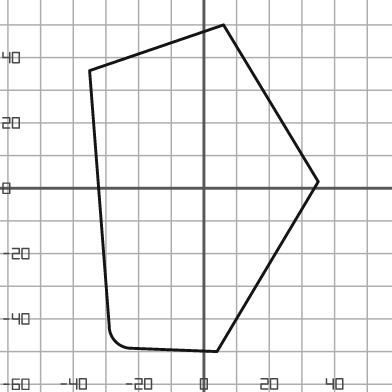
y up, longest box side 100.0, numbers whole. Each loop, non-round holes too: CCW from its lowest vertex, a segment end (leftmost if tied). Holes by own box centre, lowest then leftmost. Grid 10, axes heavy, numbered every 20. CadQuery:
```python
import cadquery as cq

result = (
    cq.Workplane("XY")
    .moveTo(4.0, -50.0)
    .lineTo(35.0, 2.0)
    .lineTo(6.0, 50.0)
    .lineTo(-35.0, 36.0)
    .lineTo(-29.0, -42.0)
    .threePointArc((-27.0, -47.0), (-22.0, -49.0))
    .close()
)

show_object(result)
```